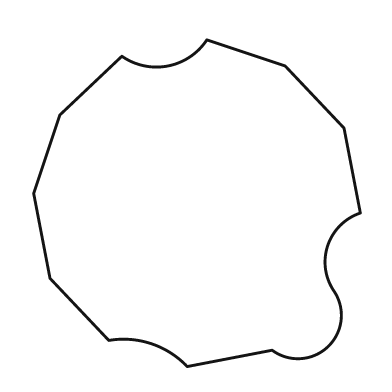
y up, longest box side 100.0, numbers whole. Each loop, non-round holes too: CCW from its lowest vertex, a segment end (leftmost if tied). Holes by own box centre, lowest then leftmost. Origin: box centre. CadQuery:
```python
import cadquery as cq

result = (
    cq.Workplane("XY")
    .moveTo(-3.0, -50.0)
    .lineTo(23.0, -45.0)
    .threePointArc((40.0, -44.0), (42.0, -27.0))
    .threePointArc((40.0, -13.0), (50.0, -3.0))
    .lineTo(45.0, 23.0)
    .lineTo(27.0, 42.0)
    .lineTo(3.0, 50.0)
    .threePointArc((-9.0, 42.0), (-23.0, 45.0))
    .lineTo(-42.0, 27.0)
    .lineTo(-50.0, 3.0)
    .lineTo(-45.0, -23.0)
    .lineTo(-27.0, -42.0)
    .threePointArc((-14.0, -43.0), (-3.0, -50.0))
    .close()
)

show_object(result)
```